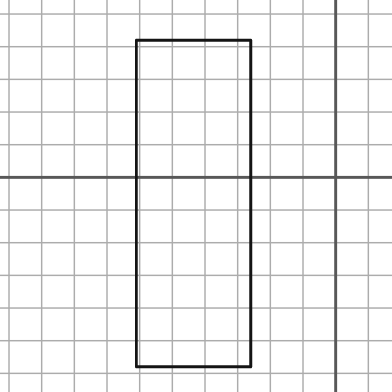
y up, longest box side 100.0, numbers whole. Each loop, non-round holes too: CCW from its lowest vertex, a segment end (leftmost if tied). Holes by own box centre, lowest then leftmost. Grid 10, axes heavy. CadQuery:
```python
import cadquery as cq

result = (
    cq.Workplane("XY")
    .moveTo(-61.0, -58.0)
    .lineTo(-26.0, -58.0)
    .lineTo(-26.0, 42.0)
    .lineTo(-61.0, 42.0)
    .close()
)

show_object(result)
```